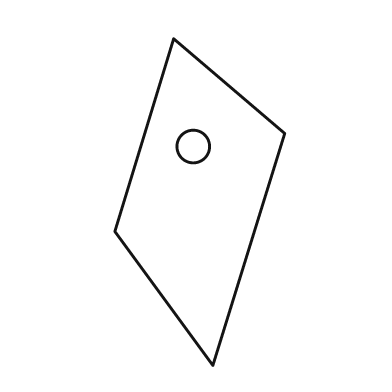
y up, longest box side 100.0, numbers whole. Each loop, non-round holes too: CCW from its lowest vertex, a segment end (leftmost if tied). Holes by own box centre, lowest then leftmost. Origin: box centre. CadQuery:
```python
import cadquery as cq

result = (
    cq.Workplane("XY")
    .moveTo(4.0, -50.0)
    .lineTo(26.0, 21.0)
    .lineTo(-8.0, 50.0)
    .lineTo(-26.0, -9.0)
    .close()
    .moveTo(-2.0, 17.0)
    .circle(5.0)
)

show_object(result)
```